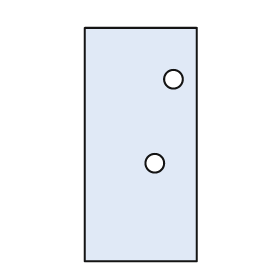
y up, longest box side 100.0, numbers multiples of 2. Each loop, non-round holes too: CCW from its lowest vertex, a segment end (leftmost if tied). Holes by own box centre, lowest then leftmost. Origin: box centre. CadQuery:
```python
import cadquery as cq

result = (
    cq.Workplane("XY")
    .moveTo(-24.0, -50.0)
    .lineTo(24.0, -50.0)
    .lineTo(24.0, 50.0)
    .lineTo(-24.0, 50.0)
    .close()
    .moveTo(6.0, -8.0)
    .circle(4.0)
    .moveTo(14.0, 28.0)
    .circle(4.0)
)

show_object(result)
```